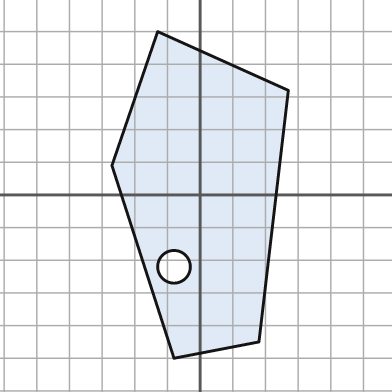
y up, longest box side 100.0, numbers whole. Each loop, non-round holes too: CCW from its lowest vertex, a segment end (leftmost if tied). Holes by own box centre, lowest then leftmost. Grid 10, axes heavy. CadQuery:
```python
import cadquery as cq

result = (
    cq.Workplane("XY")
    .moveTo(-8.0, -50.0)
    .lineTo(18.0, -45.0)
    .lineTo(27.0, 32.0)
    .lineTo(-13.0, 50.0)
    .lineTo(-27.0, 9.0)
    .close()
    .moveTo(-8.0, -22.0)
    .circle(5.0)
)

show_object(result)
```